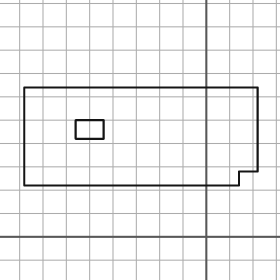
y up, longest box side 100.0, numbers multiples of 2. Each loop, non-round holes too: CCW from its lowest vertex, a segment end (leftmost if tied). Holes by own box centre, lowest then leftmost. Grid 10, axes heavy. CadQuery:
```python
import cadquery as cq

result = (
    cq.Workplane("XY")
    .moveTo(-78.0, 22.0)
    .lineTo(14.0, 22.0)
    .lineTo(14.0, 28.0)
    .lineTo(22.0, 28.0)
    .lineTo(22.0, 64.0)
    .lineTo(-78.0, 64.0)
    .close()
    .moveTo(-56.0, 42.0)
    .lineTo(-44.0, 42.0)
    .lineTo(-44.0, 50.0)
    .lineTo(-56.0, 50.0)
    .close()
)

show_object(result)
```